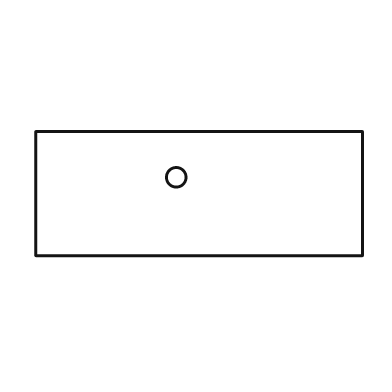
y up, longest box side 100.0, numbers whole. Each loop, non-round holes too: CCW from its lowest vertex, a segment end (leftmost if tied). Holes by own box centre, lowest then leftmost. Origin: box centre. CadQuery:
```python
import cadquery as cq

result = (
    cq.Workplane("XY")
    .moveTo(-50.0, -19.0)
    .lineTo(50.0, -19.0)
    .lineTo(50.0, 19.0)
    .lineTo(-50.0, 19.0)
    .close()
    .moveTo(-7.0, 5.0)
    .circle(3.0)
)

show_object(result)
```